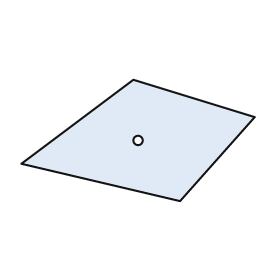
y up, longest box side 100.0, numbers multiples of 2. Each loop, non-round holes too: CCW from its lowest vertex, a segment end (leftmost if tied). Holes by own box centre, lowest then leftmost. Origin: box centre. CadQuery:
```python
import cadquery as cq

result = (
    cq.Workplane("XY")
    .moveTo(18.0, -26.0)
    .lineTo(50.0, 10.0)
    .lineTo(-2.0, 26.0)
    .lineTo(-50.0, -10.0)
    .close()
    .moveTo(0.0, 0.0)
    .circle(2.0)
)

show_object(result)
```